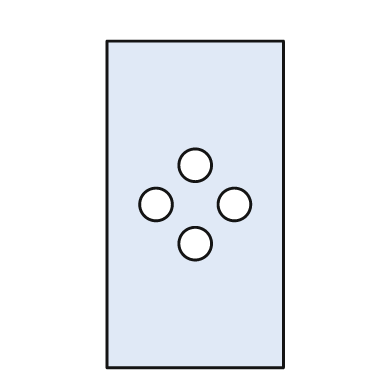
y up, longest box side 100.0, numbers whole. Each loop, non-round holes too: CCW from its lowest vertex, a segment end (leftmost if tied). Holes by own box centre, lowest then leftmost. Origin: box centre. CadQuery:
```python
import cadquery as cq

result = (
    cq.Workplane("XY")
    .moveTo(-27.0, -50.0)
    .lineTo(27.0, -50.0)
    .lineTo(27.0, 50.0)
    .lineTo(-27.0, 50.0)
    .close()
    .moveTo(0.0, -12.0)
    .circle(5.0)
    .moveTo(-12.0, 0.0)
    .circle(5.0)
    .moveTo(12.0, 0.0)
    .circle(5.0)
    .moveTo(0.0, 12.0)
    .circle(5.0)
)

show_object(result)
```